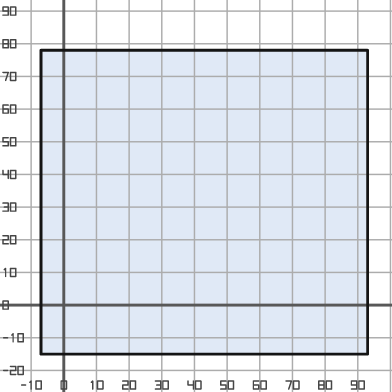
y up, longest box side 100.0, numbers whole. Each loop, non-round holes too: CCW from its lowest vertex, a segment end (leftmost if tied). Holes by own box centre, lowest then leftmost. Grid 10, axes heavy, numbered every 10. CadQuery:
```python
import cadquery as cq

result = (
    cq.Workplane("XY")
    .moveTo(-7.0, -15.0)
    .lineTo(93.0, -15.0)
    .lineTo(93.0, 78.0)
    .lineTo(-7.0, 78.0)
    .close()
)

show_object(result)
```